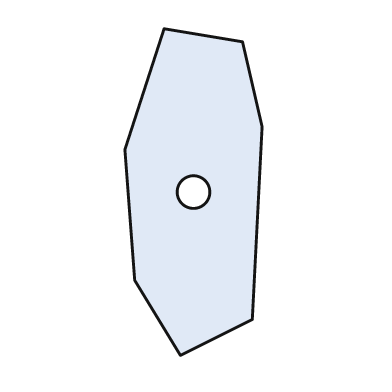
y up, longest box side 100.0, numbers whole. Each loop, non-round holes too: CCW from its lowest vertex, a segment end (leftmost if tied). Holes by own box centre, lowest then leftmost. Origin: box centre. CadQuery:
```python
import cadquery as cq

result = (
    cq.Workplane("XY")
    .moveTo(-4.0, -50.0)
    .lineTo(18.0, -39.0)
    .lineTo(21.0, 20.0)
    .lineTo(15.0, 46.0)
    .lineTo(-9.0, 50.0)
    .lineTo(-21.0, 13.0)
    .lineTo(-18.0, -27.0)
    .close()
    .moveTo(0.0, 0.0)
    .circle(5.0)
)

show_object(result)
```